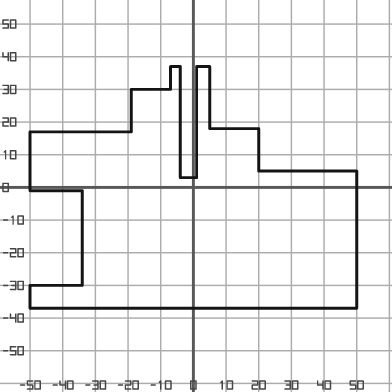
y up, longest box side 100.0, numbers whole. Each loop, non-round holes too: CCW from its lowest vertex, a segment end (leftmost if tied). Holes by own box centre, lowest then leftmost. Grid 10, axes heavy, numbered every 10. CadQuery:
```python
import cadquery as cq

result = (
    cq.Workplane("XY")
    .moveTo(-50.0, -37.0)
    .lineTo(50.0, -37.0)
    .lineTo(50.0, 5.0)
    .lineTo(20.0, 5.0)
    .lineTo(20.0, 18.0)
    .lineTo(5.0, 18.0)
    .lineTo(5.0, 37.0)
    .lineTo(1.0, 37.0)
    .lineTo(1.0, 3.0)
    .lineTo(-4.0, 3.0)
    .lineTo(-4.0, 37.0)
    .lineTo(-7.0, 37.0)
    .lineTo(-7.0, 30.0)
    .lineTo(-19.0, 30.0)
    .lineTo(-19.0, 17.0)
    .lineTo(-50.0, 17.0)
    .lineTo(-50.0, -1.0)
    .lineTo(-34.0, -1.0)
    .lineTo(-34.0, -30.0)
    .lineTo(-50.0, -30.0)
    .close()
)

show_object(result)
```